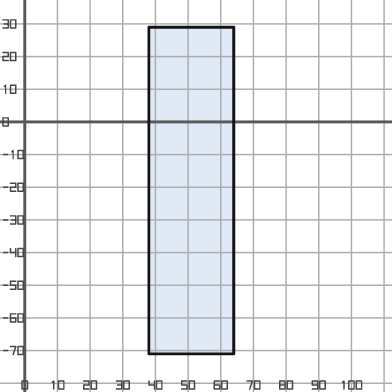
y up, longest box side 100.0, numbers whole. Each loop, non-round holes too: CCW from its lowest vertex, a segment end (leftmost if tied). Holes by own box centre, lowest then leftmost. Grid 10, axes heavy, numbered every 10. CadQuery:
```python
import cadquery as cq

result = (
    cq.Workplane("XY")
    .moveTo(38.0, -71.0)
    .lineTo(64.0, -71.0)
    .lineTo(64.0, 29.0)
    .lineTo(38.0, 29.0)
    .close()
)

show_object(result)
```